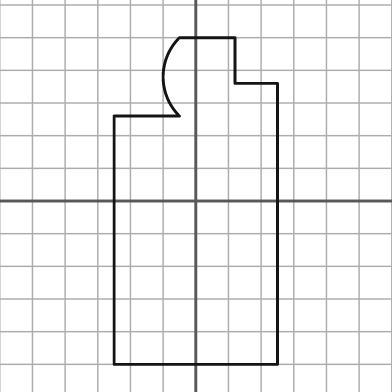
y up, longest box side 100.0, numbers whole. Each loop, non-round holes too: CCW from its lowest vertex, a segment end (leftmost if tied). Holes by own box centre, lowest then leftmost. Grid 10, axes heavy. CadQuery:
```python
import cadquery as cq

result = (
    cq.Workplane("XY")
    .moveTo(-25.0, -50.0)
    .lineTo(25.0, -50.0)
    .lineTo(25.0, 36.0)
    .lineTo(12.0, 36.0)
    .lineTo(12.0, 50.0)
    .lineTo(-5.0, 50.0)
    .threePointArc((-10.0, 38.0), (-5.0, 26.0))
    .lineTo(-25.0, 26.0)
    .close()
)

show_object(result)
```